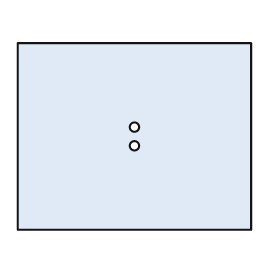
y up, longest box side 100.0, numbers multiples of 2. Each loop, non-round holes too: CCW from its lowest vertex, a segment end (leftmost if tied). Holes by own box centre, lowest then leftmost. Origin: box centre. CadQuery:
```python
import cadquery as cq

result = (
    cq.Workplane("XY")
    .moveTo(-50.0, -40.0)
    .lineTo(50.0, -40.0)
    .lineTo(50.0, 40.0)
    .lineTo(-50.0, 40.0)
    .close()
    .moveTo(0.0, -4.0)
    .circle(2.0)
    .moveTo(0.0, 4.0)
    .circle(2.0)
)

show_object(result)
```